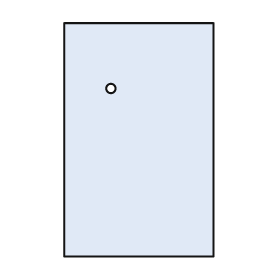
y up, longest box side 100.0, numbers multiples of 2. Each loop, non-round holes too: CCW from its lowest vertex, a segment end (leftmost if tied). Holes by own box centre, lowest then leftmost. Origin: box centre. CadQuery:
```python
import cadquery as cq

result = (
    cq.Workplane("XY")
    .moveTo(-32.0, -50.0)
    .lineTo(32.0, -50.0)
    .lineTo(32.0, 50.0)
    .lineTo(-32.0, 50.0)
    .close()
    .moveTo(-12.0, 22.0)
    .circle(2.0)
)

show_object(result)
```